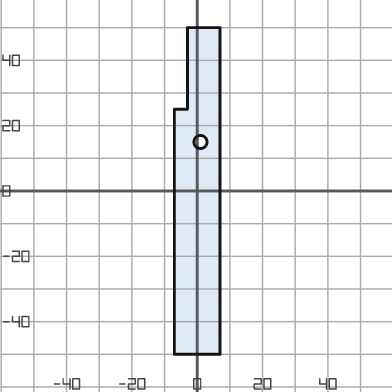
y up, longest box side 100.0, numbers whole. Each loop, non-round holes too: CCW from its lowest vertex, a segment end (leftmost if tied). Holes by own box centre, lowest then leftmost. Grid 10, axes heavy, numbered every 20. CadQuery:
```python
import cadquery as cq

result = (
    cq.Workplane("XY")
    .moveTo(-7.0, -50.0)
    .lineTo(7.0, -50.0)
    .lineTo(7.0, 50.0)
    .lineTo(-3.0, 50.0)
    .lineTo(-3.0, 25.0)
    .lineTo(-7.0, 25.0)
    .close()
    .moveTo(1.0, 15.0)
    .circle(2.0)
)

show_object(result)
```